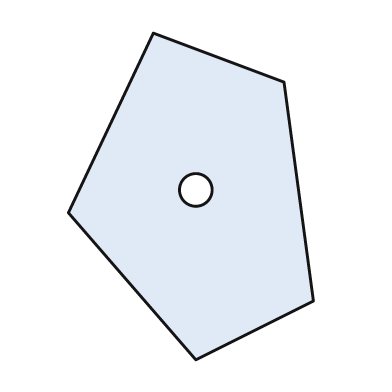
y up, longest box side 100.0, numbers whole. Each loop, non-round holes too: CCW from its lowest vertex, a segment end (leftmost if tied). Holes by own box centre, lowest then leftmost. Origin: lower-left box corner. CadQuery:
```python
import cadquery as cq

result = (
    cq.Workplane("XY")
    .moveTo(39.0, 0.0)
    .lineTo(75.0, 18.0)
    .lineTo(66.0, 85.0)
    .lineTo(26.0, 100.0)
    .lineTo(0.0, 45.0)
    .close()
    .moveTo(39.0, 52.0)
    .circle(5.0)
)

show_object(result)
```